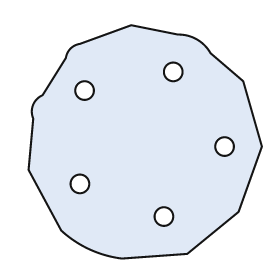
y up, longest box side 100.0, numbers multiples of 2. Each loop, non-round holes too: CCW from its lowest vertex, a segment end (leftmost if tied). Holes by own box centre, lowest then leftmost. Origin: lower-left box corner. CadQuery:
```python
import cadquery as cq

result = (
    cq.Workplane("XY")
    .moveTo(40.0, 0.0)
    .lineTo(68.0, 2.0)
    .lineTo(90.0, 20.0)
    .lineTo(100.0, 48.0)
    .lineTo(92.0, 76.0)
    .lineTo(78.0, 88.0)
    .threePointArc((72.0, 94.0), (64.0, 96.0))
    .lineTo(44.0, 100.0)
    .lineTo(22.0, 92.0)
    .threePointArc((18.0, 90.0), (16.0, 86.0))
    .lineTo(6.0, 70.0)
    .threePointArc((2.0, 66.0), (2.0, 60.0))
    .lineTo(0.0, 38.0)
    .lineTo(14.0, 12.0)
    .threePointArc((26.0, 4.0), (40.0, 0.0))
    .close()
    .moveTo(58.0, 18.0)
    .circle(4.0)
    .moveTo(22.0, 32.0)
    .circle(4.0)
    .moveTo(84.0, 48.0)
    .circle(4.0)
    .moveTo(24.0, 72.0)
    .circle(4.0)
    .moveTo(62.0, 80.0)
    .circle(4.0)
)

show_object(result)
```